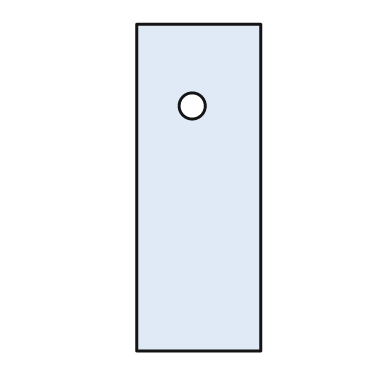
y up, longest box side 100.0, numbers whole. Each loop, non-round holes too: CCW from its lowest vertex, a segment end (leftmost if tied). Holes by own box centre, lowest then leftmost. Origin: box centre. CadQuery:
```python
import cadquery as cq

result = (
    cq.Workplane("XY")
    .moveTo(-19.0, -50.0)
    .lineTo(19.0, -50.0)
    .lineTo(19.0, 50.0)
    .lineTo(-19.0, 50.0)
    .close()
    .moveTo(-2.0, 25.0)
    .circle(4.0)
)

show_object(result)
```